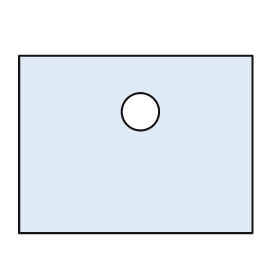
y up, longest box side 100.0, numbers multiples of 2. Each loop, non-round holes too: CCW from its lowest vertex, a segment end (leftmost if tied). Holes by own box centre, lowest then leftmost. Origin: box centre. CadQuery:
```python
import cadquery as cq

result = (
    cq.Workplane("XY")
    .moveTo(-50.0, -38.0)
    .lineTo(50.0, -38.0)
    .lineTo(50.0, 38.0)
    .lineTo(-50.0, 38.0)
    .close()
    .moveTo(2.0, 14.0)
    .circle(8.0)
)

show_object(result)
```